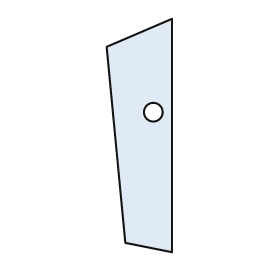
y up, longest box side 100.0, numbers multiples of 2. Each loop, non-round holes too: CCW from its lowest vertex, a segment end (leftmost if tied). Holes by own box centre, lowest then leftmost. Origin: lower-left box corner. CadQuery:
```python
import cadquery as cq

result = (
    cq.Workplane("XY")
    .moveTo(28.0, 0.0)
    .lineTo(28.0, 100.0)
    .lineTo(0.0, 88.0)
    .lineTo(8.0, 4.0)
    .close()
    .moveTo(20.0, 60.0)
    .circle(4.0)
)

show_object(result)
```